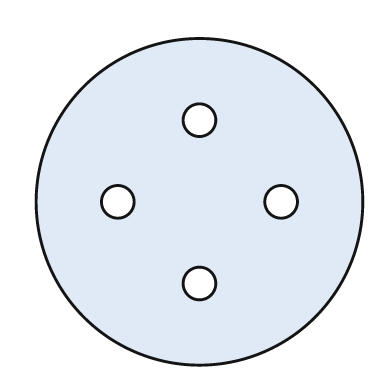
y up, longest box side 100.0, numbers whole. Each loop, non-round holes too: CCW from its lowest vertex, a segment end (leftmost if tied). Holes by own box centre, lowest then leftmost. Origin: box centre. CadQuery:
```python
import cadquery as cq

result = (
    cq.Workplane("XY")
    .moveTo(0.0, 0.0)
    .circle(50.0)
    .moveTo(0.0, -25.0)
    .circle(5.0)
    .moveTo(-25.0, 0.0)
    .circle(5.0)
    .moveTo(25.0, 0.0)
    .circle(5.0)
    .moveTo(0.0, 25.0)
    .circle(5.0)
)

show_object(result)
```